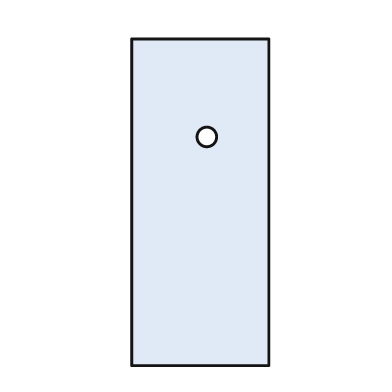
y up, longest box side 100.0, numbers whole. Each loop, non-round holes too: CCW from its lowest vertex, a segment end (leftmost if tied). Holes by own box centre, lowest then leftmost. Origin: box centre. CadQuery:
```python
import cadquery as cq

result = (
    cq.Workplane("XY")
    .moveTo(-21.0, -50.0)
    .lineTo(21.0, -50.0)
    .lineTo(21.0, 50.0)
    .lineTo(-21.0, 50.0)
    .close()
    .moveTo(2.0, 20.0)
    .circle(3.0)
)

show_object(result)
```